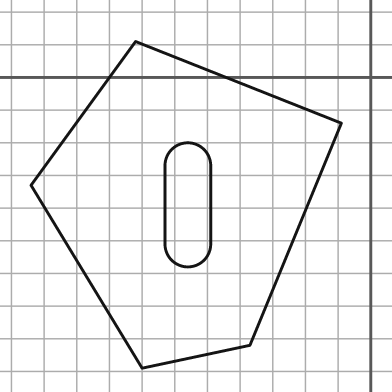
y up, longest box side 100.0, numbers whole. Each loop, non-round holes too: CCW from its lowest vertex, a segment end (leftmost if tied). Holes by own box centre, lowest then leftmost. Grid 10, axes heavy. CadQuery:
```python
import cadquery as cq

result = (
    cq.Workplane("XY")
    .moveTo(-70.0, -89.0)
    .lineTo(-37.0, -82.0)
    .lineTo(-9.0, -14.0)
    .lineTo(-72.0, 11.0)
    .lineTo(-104.0, -33.0)
    .close()
    .moveTo(-63.0, -51.0)
    .threePointArc((-56.0, -58.0), (-49.0, -51.0))
    .lineTo(-49.0, -27.0)
    .threePointArc((-56.0, -20.0), (-63.0, -27.0))
    .close()
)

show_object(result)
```